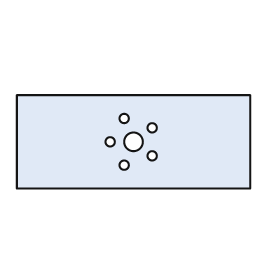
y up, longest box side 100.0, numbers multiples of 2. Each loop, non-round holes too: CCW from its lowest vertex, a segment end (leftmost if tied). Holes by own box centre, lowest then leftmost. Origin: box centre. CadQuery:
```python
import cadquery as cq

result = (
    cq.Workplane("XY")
    .moveTo(-50.0, -20.0)
    .lineTo(50.0, -20.0)
    .lineTo(50.0, 20.0)
    .lineTo(-50.0, 20.0)
    .close()
    .moveTo(-4.0, -10.0)
    .circle(2.0)
    .moveTo(8.0, -6.0)
    .circle(2.0)
    .moveTo(-10.0, 0.0)
    .circle(2.0)
    .moveTo(0.0, 0.0)
    .circle(4.0)
    .moveTo(8.0, 6.0)
    .circle(2.0)
    .moveTo(-4.0, 10.0)
    .circle(2.0)
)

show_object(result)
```